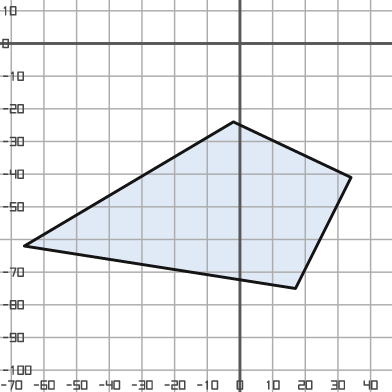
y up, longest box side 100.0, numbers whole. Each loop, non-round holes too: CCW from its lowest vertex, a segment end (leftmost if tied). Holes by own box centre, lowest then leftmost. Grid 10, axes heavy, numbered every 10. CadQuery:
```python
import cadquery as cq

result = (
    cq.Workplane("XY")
    .moveTo(17.0, -75.0)
    .lineTo(34.0, -41.0)
    .lineTo(-2.0, -24.0)
    .lineTo(-66.0, -62.0)
    .close()
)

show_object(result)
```